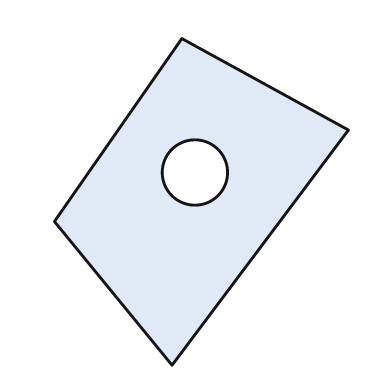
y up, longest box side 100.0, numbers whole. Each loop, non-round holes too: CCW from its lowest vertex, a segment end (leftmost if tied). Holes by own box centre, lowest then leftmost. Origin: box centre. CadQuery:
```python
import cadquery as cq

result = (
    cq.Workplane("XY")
    .moveTo(-9.0, -50.0)
    .lineTo(45.0, 22.0)
    .lineTo(-6.0, 50.0)
    .lineTo(-45.0, -6.0)
    .close()
    .moveTo(-2.0, 9.0)
    .circle(10.0)
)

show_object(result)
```